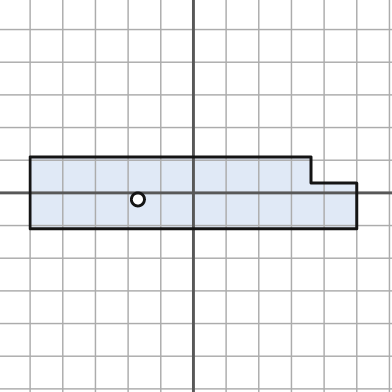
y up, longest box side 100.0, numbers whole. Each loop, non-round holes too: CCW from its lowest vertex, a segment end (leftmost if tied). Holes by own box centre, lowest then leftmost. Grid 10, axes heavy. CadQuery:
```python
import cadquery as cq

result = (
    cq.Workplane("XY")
    .moveTo(-50.0, -11.0)
    .lineTo(50.0, -11.0)
    .lineTo(50.0, 3.0)
    .lineTo(36.0, 3.0)
    .lineTo(36.0, 11.0)
    .lineTo(-50.0, 11.0)
    .close()
    .moveTo(-17.0, -2.0)
    .circle(2.0)
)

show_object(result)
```